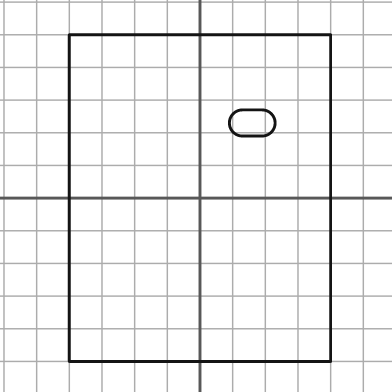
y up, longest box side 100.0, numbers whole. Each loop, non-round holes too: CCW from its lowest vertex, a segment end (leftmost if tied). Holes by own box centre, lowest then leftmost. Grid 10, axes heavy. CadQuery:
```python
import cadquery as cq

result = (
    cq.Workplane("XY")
    .moveTo(-40.0, -50.0)
    .lineTo(40.0, -50.0)
    .lineTo(40.0, 50.0)
    .lineTo(-40.0, 50.0)
    .close()
    .moveTo(13.0, 19.0)
    .lineTo(19.0, 19.0)
    .threePointArc((23.0, 23.0), (19.0, 27.0))
    .lineTo(13.0, 27.0)
    .threePointArc((9.0, 23.0), (13.0, 19.0))
    .close()
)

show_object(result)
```